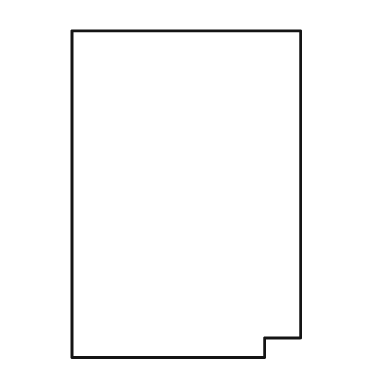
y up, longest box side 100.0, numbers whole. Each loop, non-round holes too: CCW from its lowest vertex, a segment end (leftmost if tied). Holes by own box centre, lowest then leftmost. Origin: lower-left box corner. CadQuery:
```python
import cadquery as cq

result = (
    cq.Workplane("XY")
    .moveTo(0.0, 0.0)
    .lineTo(59.0, 0.0)
    .lineTo(59.0, 6.0)
    .lineTo(70.0, 6.0)
    .lineTo(70.0, 100.0)
    .lineTo(0.0, 100.0)
    .close()
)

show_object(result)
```